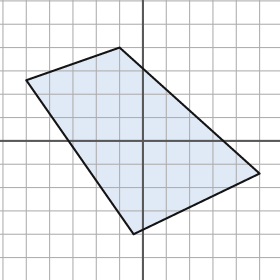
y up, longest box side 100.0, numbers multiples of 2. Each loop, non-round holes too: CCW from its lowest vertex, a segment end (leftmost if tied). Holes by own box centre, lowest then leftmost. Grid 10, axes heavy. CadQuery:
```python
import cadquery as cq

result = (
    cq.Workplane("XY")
    .moveTo(-4.0, -40.0)
    .lineTo(50.0, -14.0)
    .lineTo(-10.0, 40.0)
    .lineTo(-50.0, 26.0)
    .close()
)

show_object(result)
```